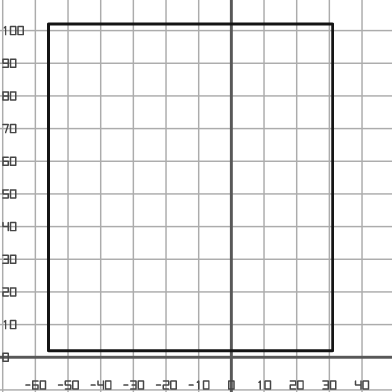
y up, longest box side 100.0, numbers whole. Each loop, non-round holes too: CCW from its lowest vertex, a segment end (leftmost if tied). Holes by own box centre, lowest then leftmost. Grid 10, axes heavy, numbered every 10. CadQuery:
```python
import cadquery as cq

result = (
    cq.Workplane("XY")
    .moveTo(-56.0, 2.0)
    .lineTo(31.0, 2.0)
    .lineTo(31.0, 102.0)
    .lineTo(-56.0, 102.0)
    .close()
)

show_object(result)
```